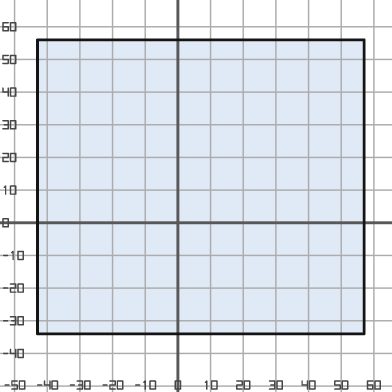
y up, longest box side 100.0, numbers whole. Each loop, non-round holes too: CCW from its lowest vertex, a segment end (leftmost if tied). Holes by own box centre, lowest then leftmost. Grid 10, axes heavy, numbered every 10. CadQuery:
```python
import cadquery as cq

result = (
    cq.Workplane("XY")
    .moveTo(-43.0, -34.0)
    .lineTo(57.0, -34.0)
    .lineTo(57.0, 56.0)
    .lineTo(-43.0, 56.0)
    .close()
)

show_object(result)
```